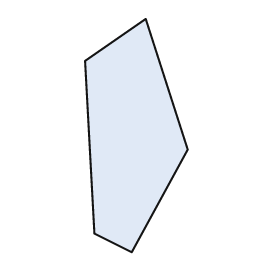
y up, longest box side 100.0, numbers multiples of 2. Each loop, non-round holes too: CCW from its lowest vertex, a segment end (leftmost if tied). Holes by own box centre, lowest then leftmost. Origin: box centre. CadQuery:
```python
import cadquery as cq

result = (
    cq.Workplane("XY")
    .moveTo(-2.0, -50.0)
    .lineTo(22.0, -6.0)
    .lineTo(4.0, 50.0)
    .lineTo(-22.0, 32.0)
    .lineTo(-18.0, -42.0)
    .close()
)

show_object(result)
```